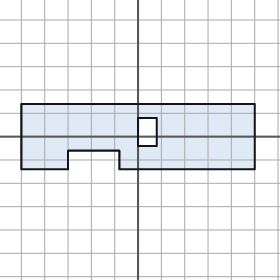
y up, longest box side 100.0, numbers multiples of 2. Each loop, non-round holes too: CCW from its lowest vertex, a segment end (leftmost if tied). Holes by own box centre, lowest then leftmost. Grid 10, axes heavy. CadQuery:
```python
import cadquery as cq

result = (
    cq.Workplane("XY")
    .moveTo(-50.0, -14.0)
    .lineTo(-30.0, -14.0)
    .lineTo(-30.0, -6.0)
    .lineTo(-8.0, -6.0)
    .lineTo(-8.0, -14.0)
    .lineTo(50.0, -14.0)
    .lineTo(50.0, 14.0)
    .lineTo(-50.0, 14.0)
    .close()
    .moveTo(0.0, -4.0)
    .lineTo(8.0, -4.0)
    .lineTo(8.0, 8.0)
    .lineTo(0.0, 8.0)
    .close()
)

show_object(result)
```